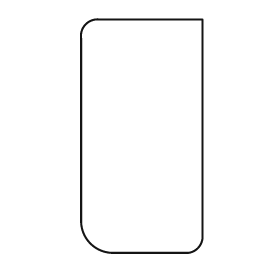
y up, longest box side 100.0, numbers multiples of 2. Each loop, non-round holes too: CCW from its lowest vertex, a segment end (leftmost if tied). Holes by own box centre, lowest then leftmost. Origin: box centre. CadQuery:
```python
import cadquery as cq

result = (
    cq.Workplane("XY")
    .moveTo(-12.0, -50.0)
    .lineTo(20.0, -50.0)
    .threePointArc((24.0, -48.0), (26.0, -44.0))
    .lineTo(26.0, 50.0)
    .lineTo(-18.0, 50.0)
    .threePointArc((-24.0, 48.0), (-26.0, 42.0))
    .lineTo(-26.0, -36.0)
    .threePointArc((-22.0, -46.0), (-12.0, -50.0))
    .close()
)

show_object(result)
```